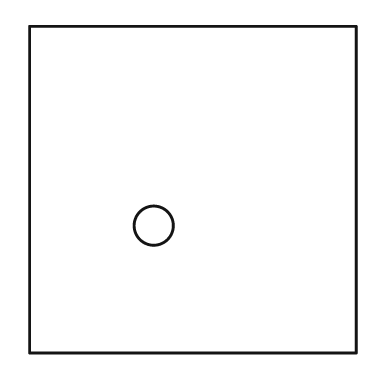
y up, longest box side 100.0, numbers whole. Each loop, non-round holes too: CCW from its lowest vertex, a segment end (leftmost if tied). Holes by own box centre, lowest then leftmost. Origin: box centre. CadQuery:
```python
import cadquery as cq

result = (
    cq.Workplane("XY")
    .moveTo(-50.0, -50.0)
    .lineTo(50.0, -50.0)
    .lineTo(50.0, 50.0)
    .lineTo(-50.0, 50.0)
    .close()
    .moveTo(-12.0, -11.0)
    .circle(6.0)
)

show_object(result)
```